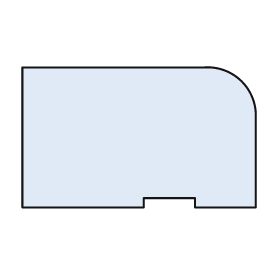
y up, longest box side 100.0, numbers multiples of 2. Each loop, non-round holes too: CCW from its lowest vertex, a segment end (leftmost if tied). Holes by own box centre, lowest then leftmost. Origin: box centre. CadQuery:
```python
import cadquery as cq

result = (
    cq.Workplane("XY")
    .moveTo(-50.0, -30.0)
    .lineTo(2.0, -30.0)
    .lineTo(2.0, -26.0)
    .lineTo(24.0, -26.0)
    .lineTo(24.0, -30.0)
    .lineTo(50.0, -30.0)
    .lineTo(50.0, 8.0)
    .threePointArc((44.0, 24.0), (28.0, 30.0))
    .lineTo(-50.0, 30.0)
    .close()
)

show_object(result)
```